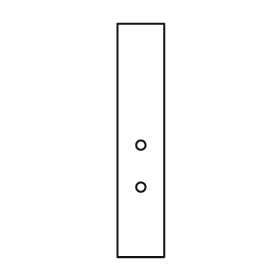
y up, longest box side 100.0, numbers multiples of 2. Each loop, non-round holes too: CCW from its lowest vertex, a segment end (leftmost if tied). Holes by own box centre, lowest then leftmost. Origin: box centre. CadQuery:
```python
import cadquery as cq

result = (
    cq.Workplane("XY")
    .moveTo(-10.0, -50.0)
    .lineTo(10.0, -50.0)
    .lineTo(10.0, 50.0)
    .lineTo(-10.0, 50.0)
    .close()
    .moveTo(0.0, -20.0)
    .circle(2.0)
    .moveTo(0.0, -2.0)
    .circle(2.0)
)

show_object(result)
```